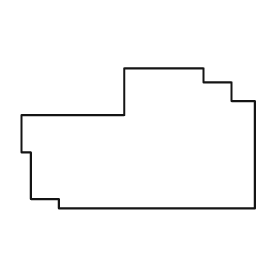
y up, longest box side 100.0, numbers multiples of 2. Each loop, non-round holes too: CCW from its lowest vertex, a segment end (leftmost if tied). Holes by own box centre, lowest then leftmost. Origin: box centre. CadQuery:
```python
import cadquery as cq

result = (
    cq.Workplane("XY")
    .moveTo(-34.0, -30.0)
    .lineTo(50.0, -30.0)
    .lineTo(50.0, 16.0)
    .lineTo(40.0, 16.0)
    .lineTo(40.0, 24.0)
    .lineTo(28.0, 24.0)
    .lineTo(28.0, 30.0)
    .lineTo(-6.0, 30.0)
    .lineTo(-6.0, 10.0)
    .lineTo(-50.0, 10.0)
    .lineTo(-50.0, -6.0)
    .lineTo(-46.0, -6.0)
    .lineTo(-46.0, -26.0)
    .lineTo(-34.0, -26.0)
    .close()
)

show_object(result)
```